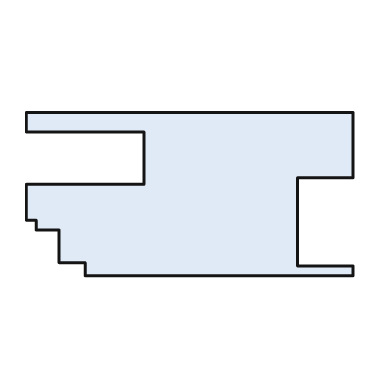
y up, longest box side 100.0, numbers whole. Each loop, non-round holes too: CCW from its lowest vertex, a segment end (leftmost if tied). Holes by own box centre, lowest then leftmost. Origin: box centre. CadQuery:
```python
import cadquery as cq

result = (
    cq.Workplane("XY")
    .moveTo(-32.0, -25.0)
    .lineTo(50.0, -25.0)
    .lineTo(50.0, -22.0)
    .lineTo(33.0, -22.0)
    .lineTo(33.0, 5.0)
    .lineTo(50.0, 5.0)
    .lineTo(50.0, 25.0)
    .lineTo(-50.0, 25.0)
    .lineTo(-50.0, 19.0)
    .lineTo(-14.0, 19.0)
    .lineTo(-14.0, 3.0)
    .lineTo(-50.0, 3.0)
    .lineTo(-50.0, -8.0)
    .lineTo(-47.0, -8.0)
    .lineTo(-47.0, -11.0)
    .lineTo(-40.0, -11.0)
    .lineTo(-40.0, -21.0)
    .lineTo(-32.0, -21.0)
    .close()
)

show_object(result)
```